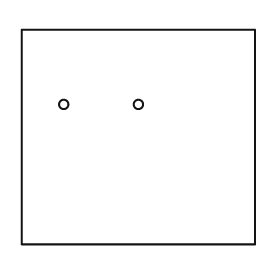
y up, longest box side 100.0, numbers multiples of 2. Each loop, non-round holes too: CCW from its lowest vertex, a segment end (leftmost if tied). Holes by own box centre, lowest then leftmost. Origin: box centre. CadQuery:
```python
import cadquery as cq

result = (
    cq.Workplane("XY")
    .moveTo(-50.0, -46.0)
    .lineTo(50.0, -46.0)
    .lineTo(50.0, 46.0)
    .lineTo(-50.0, 46.0)
    .close()
    .moveTo(-32.0, 14.0)
    .circle(2.0)
    .moveTo(0.0, 14.0)
    .circle(2.0)
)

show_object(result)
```